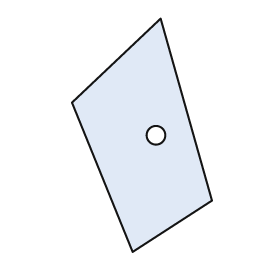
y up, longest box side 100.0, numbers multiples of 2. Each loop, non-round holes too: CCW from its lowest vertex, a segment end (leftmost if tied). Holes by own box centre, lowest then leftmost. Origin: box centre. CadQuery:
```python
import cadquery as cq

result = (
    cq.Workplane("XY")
    .moveTo(-4.0, -50.0)
    .lineTo(30.0, -28.0)
    .lineTo(8.0, 50.0)
    .lineTo(-30.0, 14.0)
    .close()
    .moveTo(6.0, 0.0)
    .circle(4.0)
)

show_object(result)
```